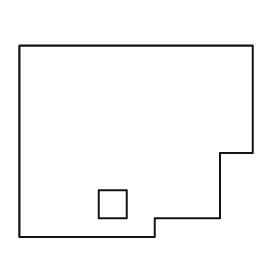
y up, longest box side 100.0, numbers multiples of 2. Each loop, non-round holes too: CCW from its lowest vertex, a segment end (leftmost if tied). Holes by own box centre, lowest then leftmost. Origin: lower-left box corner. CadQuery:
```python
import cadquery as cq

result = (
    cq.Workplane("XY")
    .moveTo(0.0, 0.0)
    .lineTo(58.0, 0.0)
    .lineTo(58.0, 8.0)
    .lineTo(86.0, 8.0)
    .lineTo(86.0, 36.0)
    .lineTo(100.0, 36.0)
    .lineTo(100.0, 82.0)
    .lineTo(0.0, 82.0)
    .close()
    .moveTo(34.0, 8.0)
    .lineTo(46.0, 8.0)
    .lineTo(46.0, 20.0)
    .lineTo(34.0, 20.0)
    .close()
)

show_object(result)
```